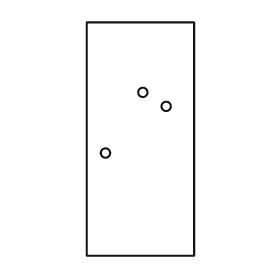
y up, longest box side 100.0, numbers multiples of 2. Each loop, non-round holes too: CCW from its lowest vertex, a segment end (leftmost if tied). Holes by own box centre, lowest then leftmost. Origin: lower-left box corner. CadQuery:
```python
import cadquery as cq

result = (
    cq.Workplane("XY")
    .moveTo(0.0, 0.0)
    .lineTo(46.0, 0.0)
    .lineTo(46.0, 100.0)
    .lineTo(0.0, 100.0)
    .close()
    .moveTo(8.0, 44.0)
    .circle(2.0)
    .moveTo(34.0, 64.0)
    .circle(2.0)
    .moveTo(24.0, 70.0)
    .circle(2.0)
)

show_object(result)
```